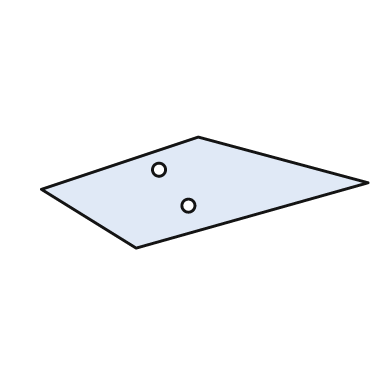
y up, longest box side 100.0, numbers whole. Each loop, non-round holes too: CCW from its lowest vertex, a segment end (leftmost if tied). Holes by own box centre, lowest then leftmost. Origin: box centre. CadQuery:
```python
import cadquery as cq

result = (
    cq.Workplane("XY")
    .moveTo(-21.0, -17.0)
    .lineTo(50.0, 3.0)
    .lineTo(-2.0, 17.0)
    .lineTo(-50.0, 1.0)
    .close()
    .moveTo(-5.0, -4.0)
    .circle(2.0)
    .moveTo(-14.0, 7.0)
    .circle(2.0)
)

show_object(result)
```